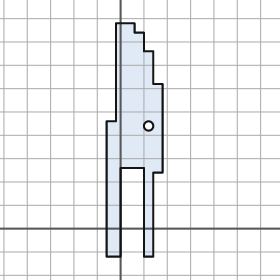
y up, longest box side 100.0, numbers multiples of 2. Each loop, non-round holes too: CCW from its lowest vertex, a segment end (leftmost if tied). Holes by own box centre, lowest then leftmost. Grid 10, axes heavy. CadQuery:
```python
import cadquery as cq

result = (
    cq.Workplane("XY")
    .moveTo(-6.0, -12.0)
    .lineTo(0.0, -12.0)
    .lineTo(0.0, 26.0)
    .lineTo(10.0, 26.0)
    .lineTo(10.0, -12.0)
    .lineTo(14.0, -12.0)
    .lineTo(14.0, 24.0)
    .lineTo(18.0, 24.0)
    .lineTo(18.0, 62.0)
    .lineTo(14.0, 62.0)
    .lineTo(14.0, 76.0)
    .lineTo(10.0, 76.0)
    .lineTo(10.0, 84.0)
    .lineTo(6.0, 84.0)
    .lineTo(6.0, 88.0)
    .lineTo(-2.0, 88.0)
    .lineTo(-2.0, 46.0)
    .lineTo(-6.0, 46.0)
    .close()
    .moveTo(12.0, 44.0)
    .circle(2.0)
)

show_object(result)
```